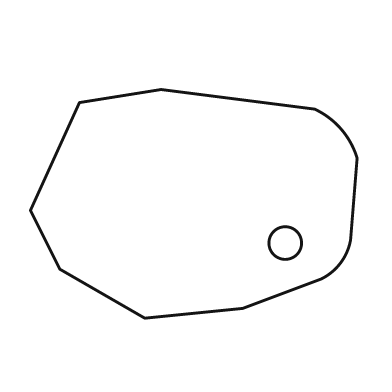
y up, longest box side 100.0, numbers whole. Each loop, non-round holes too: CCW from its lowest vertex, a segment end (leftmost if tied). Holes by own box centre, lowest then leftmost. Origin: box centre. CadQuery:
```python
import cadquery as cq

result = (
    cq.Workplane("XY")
    .moveTo(-15.0, -35.0)
    .lineTo(15.0, -32.0)
    .lineTo(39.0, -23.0)
    .threePointArc((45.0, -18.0), (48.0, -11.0))
    .lineTo(50.0, 14.0)
    .threePointArc((45.0, 23.0), (37.0, 29.0))
    .lineTo(-10.0, 35.0)
    .lineTo(-35.0, 31.0)
    .lineTo(-50.0, -2.0)
    .lineTo(-41.0, -20.0)
    .close()
    .moveTo(28.0, -12.0)
    .circle(5.0)
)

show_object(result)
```